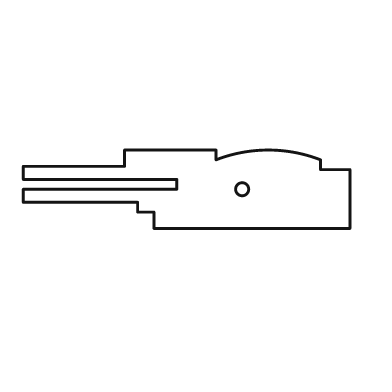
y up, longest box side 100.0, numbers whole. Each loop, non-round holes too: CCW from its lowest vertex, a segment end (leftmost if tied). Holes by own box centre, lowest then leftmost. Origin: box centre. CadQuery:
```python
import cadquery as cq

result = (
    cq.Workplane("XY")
    .moveTo(-10.0, -12.0)
    .lineTo(50.0, -12.0)
    .lineTo(50.0, 6.0)
    .lineTo(41.0, 6.0)
    .lineTo(41.0, 9.0)
    .threePointArc((25.0, 12.0), (9.0, 9.0))
    .lineTo(9.0, 12.0)
    .lineTo(-19.0, 12.0)
    .lineTo(-19.0, 7.0)
    .lineTo(-50.0, 7.0)
    .lineTo(-50.0, 3.0)
    .lineTo(-3.0, 3.0)
    .lineTo(-3.0, 0.0)
    .lineTo(-50.0, 0.0)
    .lineTo(-50.0, -4.0)
    .lineTo(-15.0, -4.0)
    .lineTo(-15.0, -7.0)
    .lineTo(-10.0, -7.0)
    .close()
    .moveTo(17.0, 0.0)
    .circle(2.0)
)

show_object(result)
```